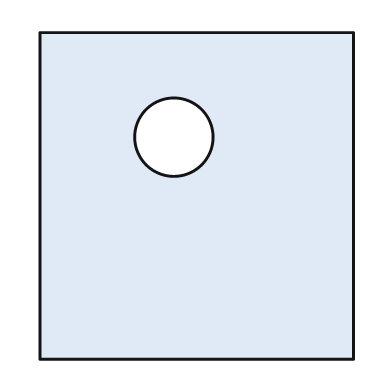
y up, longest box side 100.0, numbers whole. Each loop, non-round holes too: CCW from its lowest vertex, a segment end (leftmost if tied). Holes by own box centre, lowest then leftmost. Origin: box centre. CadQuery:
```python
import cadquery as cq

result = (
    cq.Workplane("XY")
    .moveTo(-48.0, -50.0)
    .lineTo(48.0, -50.0)
    .lineTo(48.0, 50.0)
    .lineTo(-48.0, 50.0)
    .close()
    .moveTo(-7.0, 18.0)
    .circle(12.0)
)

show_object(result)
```